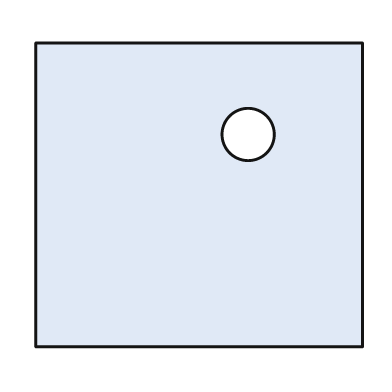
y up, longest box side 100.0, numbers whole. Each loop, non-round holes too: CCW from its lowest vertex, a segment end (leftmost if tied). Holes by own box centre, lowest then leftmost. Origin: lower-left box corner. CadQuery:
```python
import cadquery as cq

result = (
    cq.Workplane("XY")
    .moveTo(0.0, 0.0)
    .lineTo(100.0, 0.0)
    .lineTo(100.0, 93.0)
    .lineTo(0.0, 93.0)
    .close()
    .moveTo(65.0, 65.0)
    .circle(8.0)
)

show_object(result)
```